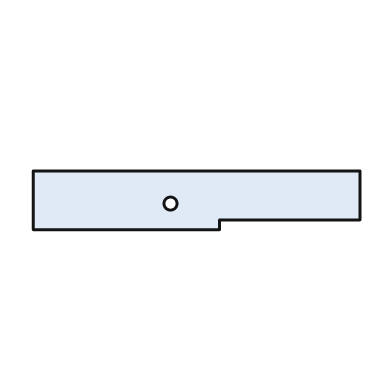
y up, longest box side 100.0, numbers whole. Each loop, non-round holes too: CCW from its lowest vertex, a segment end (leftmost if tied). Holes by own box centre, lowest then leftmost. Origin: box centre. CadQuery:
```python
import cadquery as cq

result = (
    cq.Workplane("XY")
    .moveTo(-50.0, -9.0)
    .lineTo(7.0, -9.0)
    .lineTo(7.0, -6.0)
    .lineTo(50.0, -6.0)
    .lineTo(50.0, 9.0)
    .lineTo(-50.0, 9.0)
    .close()
    .moveTo(-8.0, -1.0)
    .circle(2.0)
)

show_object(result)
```